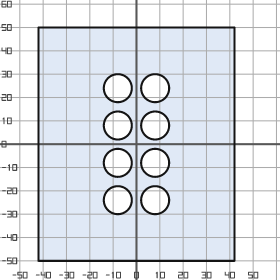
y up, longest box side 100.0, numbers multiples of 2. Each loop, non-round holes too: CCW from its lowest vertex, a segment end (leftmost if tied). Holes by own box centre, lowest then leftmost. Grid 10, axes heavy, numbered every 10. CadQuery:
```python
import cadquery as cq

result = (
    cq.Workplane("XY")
    .moveTo(-42.0, -50.0)
    .lineTo(42.0, -50.0)
    .lineTo(42.0, 50.0)
    .lineTo(-42.0, 50.0)
    .close()
    .moveTo(-8.0, -24.0)
    .circle(6.0)
    .moveTo(8.0, -24.0)
    .circle(6.0)
    .moveTo(-8.0, -8.0)
    .circle(6.0)
    .moveTo(8.0, -8.0)
    .circle(6.0)
    .moveTo(-8.0, 8.0)
    .circle(6.0)
    .moveTo(8.0, 8.0)
    .circle(6.0)
    .moveTo(-8.0, 24.0)
    .circle(6.0)
    .moveTo(8.0, 24.0)
    .circle(6.0)
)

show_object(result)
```